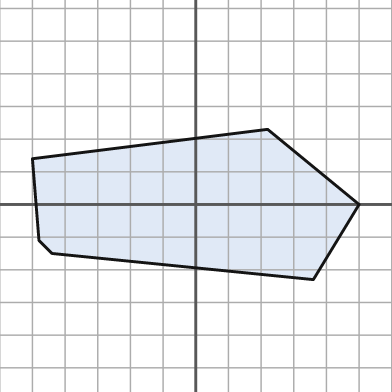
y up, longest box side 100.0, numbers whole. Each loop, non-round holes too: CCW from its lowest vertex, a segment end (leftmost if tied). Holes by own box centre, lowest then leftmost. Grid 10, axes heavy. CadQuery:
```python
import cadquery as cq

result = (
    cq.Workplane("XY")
    .moveTo(36.0, -23.0)
    .lineTo(50.0, 0.0)
    .lineTo(22.0, 23.0)
    .lineTo(-50.0, 14.0)
    .lineTo(-48.0, -11.0)
    .lineTo(-44.0, -15.0)
    .close()
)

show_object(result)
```